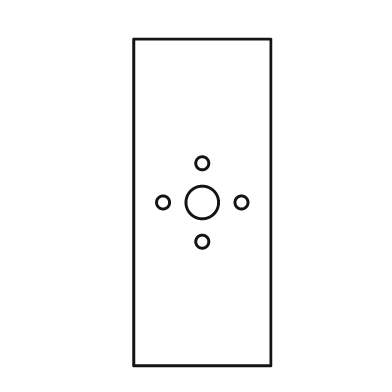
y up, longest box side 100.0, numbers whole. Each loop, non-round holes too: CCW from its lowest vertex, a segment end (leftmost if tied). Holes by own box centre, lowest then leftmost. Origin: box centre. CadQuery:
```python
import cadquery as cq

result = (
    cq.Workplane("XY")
    .moveTo(-21.0, -50.0)
    .lineTo(21.0, -50.0)
    .lineTo(21.0, 50.0)
    .lineTo(-21.0, 50.0)
    .close()
    .moveTo(0.0, -12.0)
    .circle(2.0)
    .moveTo(-12.0, 0.0)
    .circle(2.0)
    .moveTo(0.0, 0.0)
    .circle(5.0)
    .moveTo(12.0, 0.0)
    .circle(2.0)
    .moveTo(0.0, 12.0)
    .circle(2.0)
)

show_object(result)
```